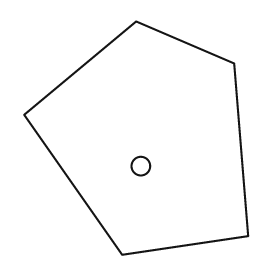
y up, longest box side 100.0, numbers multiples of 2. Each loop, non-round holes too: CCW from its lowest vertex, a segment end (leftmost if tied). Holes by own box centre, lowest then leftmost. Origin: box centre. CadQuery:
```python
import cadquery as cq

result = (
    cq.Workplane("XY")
    .moveTo(-6.0, -50.0)
    .lineTo(48.0, -42.0)
    .lineTo(42.0, 32.0)
    .lineTo(0.0, 50.0)
    .lineTo(-48.0, 10.0)
    .close()
    .moveTo(2.0, -12.0)
    .circle(4.0)
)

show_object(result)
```